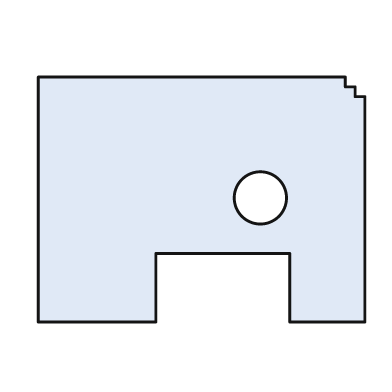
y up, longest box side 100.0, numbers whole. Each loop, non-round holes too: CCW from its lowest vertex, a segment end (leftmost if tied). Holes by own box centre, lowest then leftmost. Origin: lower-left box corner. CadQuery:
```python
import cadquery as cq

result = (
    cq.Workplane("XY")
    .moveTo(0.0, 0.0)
    .lineTo(36.0, 0.0)
    .lineTo(36.0, 21.0)
    .lineTo(77.0, 21.0)
    .lineTo(77.0, 0.0)
    .lineTo(100.0, 0.0)
    .lineTo(100.0, 69.0)
    .lineTo(97.0, 69.0)
    .lineTo(97.0, 72.0)
    .lineTo(94.0, 72.0)
    .lineTo(94.0, 75.0)
    .lineTo(0.0, 75.0)
    .close()
    .moveTo(68.0, 38.0)
    .circle(8.0)
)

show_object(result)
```